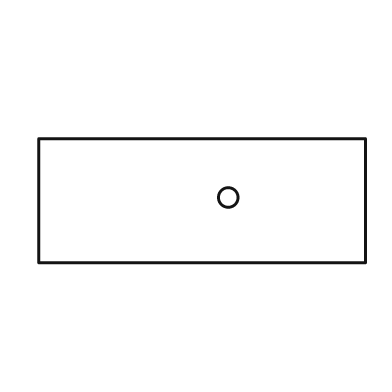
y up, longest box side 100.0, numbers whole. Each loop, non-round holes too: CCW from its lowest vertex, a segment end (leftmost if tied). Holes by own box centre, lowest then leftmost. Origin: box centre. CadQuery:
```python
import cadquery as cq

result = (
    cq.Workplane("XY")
    .moveTo(-50.0, -19.0)
    .lineTo(50.0, -19.0)
    .lineTo(50.0, 19.0)
    .lineTo(-50.0, 19.0)
    .close()
    .moveTo(8.0, 1.0)
    .circle(3.0)
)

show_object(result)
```